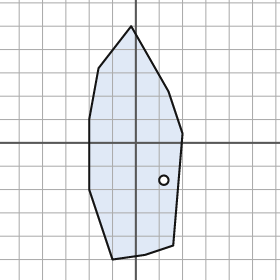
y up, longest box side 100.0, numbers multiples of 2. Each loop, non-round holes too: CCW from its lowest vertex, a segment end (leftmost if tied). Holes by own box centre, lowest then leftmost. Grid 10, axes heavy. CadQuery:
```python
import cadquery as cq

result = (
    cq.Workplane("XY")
    .moveTo(-10.0, -50.0)
    .lineTo(4.0, -48.0)
    .lineTo(16.0, -44.0)
    .lineTo(20.0, 4.0)
    .lineTo(14.0, 22.0)
    .lineTo(-2.0, 50.0)
    .lineTo(-16.0, 32.0)
    .lineTo(-20.0, 10.0)
    .lineTo(-20.0, -20.0)
    .close()
    .moveTo(12.0, -16.0)
    .circle(2.0)
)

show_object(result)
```